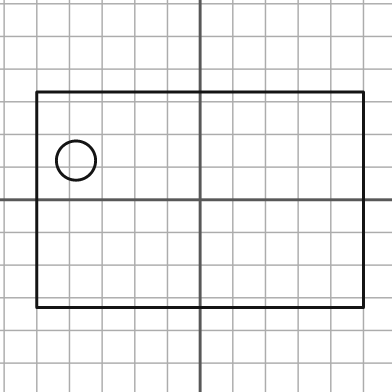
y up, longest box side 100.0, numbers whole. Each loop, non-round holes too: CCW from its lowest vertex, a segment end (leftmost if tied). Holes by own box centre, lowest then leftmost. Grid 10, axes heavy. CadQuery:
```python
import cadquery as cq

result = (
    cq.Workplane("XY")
    .moveTo(-50.0, -33.0)
    .lineTo(50.0, -33.0)
    .lineTo(50.0, 33.0)
    .lineTo(-50.0, 33.0)
    .close()
    .moveTo(-38.0, 12.0)
    .circle(6.0)
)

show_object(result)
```